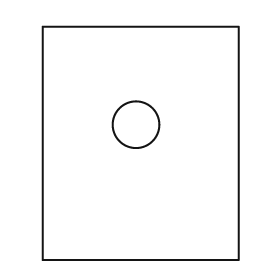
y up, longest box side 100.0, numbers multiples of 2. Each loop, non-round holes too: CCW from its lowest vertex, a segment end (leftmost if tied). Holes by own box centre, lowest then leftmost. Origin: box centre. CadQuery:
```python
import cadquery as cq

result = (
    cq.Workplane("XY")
    .moveTo(-42.0, -50.0)
    .lineTo(42.0, -50.0)
    .lineTo(42.0, 50.0)
    .lineTo(-42.0, 50.0)
    .close()
    .moveTo(-2.0, 8.0)
    .circle(10.0)
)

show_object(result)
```